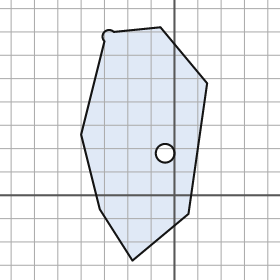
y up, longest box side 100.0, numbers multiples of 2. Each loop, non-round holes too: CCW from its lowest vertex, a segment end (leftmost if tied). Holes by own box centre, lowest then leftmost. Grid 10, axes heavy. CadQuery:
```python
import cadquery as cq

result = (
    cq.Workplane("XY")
    .moveTo(-18.0, -28.0)
    .lineTo(6.0, -8.0)
    .lineTo(14.0, 48.0)
    .lineTo(-6.0, 72.0)
    .lineTo(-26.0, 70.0)
    .threePointArc((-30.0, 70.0), (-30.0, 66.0))
    .lineTo(-40.0, 26.0)
    .lineTo(-32.0, -6.0)
    .close()
    .moveTo(-4.0, 18.0)
    .circle(4.0)
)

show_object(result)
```